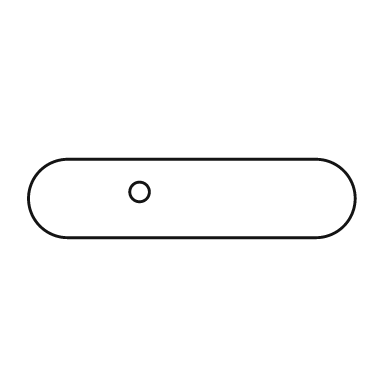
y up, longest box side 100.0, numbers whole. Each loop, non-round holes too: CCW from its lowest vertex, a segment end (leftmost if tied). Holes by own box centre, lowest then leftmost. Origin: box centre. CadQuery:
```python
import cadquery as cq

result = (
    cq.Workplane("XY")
    .moveTo(-38.0, -12.0)
    .lineTo(38.0, -12.0)
    .threePointArc((50.0, 0.0), (38.0, 12.0))
    .lineTo(-38.0, 12.0)
    .threePointArc((-50.0, 0.0), (-38.0, -12.0))
    .close()
    .moveTo(-16.0, 2.0)
    .circle(3.0)
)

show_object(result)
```